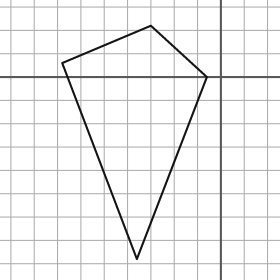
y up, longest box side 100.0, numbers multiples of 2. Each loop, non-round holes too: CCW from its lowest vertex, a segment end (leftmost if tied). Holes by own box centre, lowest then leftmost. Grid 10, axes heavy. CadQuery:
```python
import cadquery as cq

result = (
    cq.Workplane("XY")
    .moveTo(-36.0, -78.0)
    .lineTo(-6.0, 0.0)
    .lineTo(-30.0, 22.0)
    .lineTo(-68.0, 6.0)
    .close()
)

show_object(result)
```